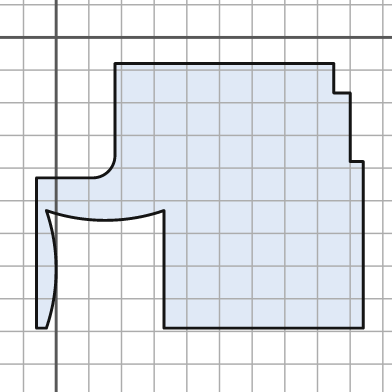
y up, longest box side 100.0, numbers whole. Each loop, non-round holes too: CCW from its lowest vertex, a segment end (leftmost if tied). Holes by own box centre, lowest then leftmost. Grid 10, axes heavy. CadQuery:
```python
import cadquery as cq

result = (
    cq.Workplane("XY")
    .moveTo(-6.0, -89.0)
    .lineTo(-3.0, -89.0)
    .threePointArc((0.0, -71.0), (-3.0, -53.0))
    .threePointArc((15.0, -56.0), (33.0, -53.0))
    .lineTo(33.0, -89.0)
    .lineTo(94.0, -89.0)
    .lineTo(94.0, -38.0)
    .lineTo(90.0, -38.0)
    .lineTo(90.0, -17.0)
    .lineTo(85.0, -17.0)
    .lineTo(85.0, -8.0)
    .lineTo(18.0, -8.0)
    .lineTo(18.0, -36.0)
    .threePointArc((16.0, -41.0), (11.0, -43.0))
    .lineTo(-6.0, -43.0)
    .close()
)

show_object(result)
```